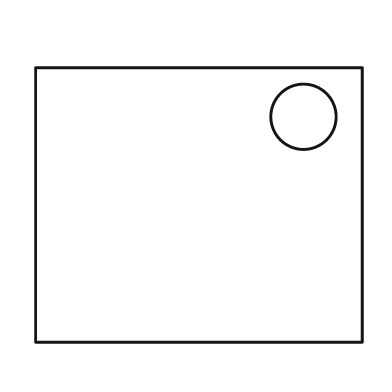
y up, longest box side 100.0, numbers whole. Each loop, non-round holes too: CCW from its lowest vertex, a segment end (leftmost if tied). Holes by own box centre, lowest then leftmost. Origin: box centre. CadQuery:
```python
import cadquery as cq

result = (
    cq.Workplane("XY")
    .moveTo(-50.0, -42.0)
    .lineTo(50.0, -42.0)
    .lineTo(50.0, 42.0)
    .lineTo(-50.0, 42.0)
    .close()
    .moveTo(32.0, 27.0)
    .circle(10.0)
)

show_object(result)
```